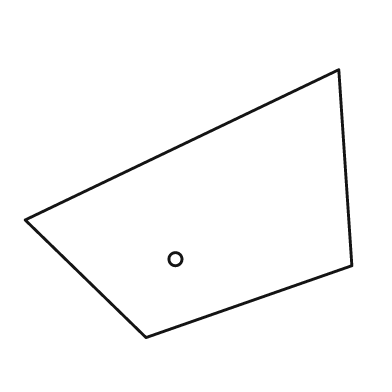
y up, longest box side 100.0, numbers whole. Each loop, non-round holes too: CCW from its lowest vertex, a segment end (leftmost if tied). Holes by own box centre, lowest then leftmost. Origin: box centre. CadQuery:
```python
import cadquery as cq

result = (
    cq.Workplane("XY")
    .moveTo(-13.0, -41.0)
    .lineTo(50.0, -19.0)
    .lineTo(46.0, 41.0)
    .lineTo(-50.0, -5.0)
    .close()
    .moveTo(-4.0, -17.0)
    .circle(2.0)
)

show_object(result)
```